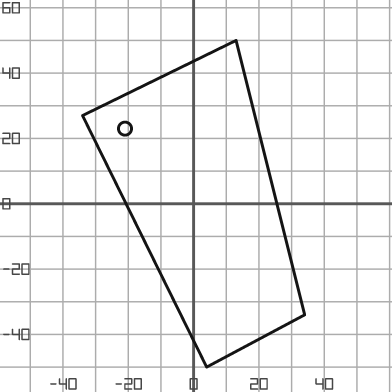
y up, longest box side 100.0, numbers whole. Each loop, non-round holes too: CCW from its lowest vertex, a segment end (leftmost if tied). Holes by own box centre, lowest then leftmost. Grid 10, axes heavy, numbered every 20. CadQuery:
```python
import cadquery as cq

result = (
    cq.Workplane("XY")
    .moveTo(4.0, -50.0)
    .lineTo(34.0, -34.0)
    .lineTo(13.0, 50.0)
    .lineTo(-34.0, 27.0)
    .close()
    .moveTo(-21.0, 23.0)
    .circle(2.0)
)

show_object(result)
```